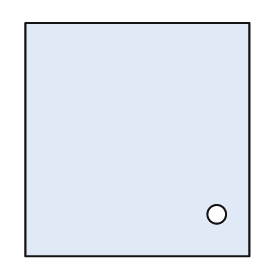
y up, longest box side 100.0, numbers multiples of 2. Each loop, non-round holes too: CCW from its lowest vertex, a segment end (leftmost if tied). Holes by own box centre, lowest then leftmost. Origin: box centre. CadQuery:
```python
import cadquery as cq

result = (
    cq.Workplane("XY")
    .moveTo(-48.0, -50.0)
    .lineTo(48.0, -50.0)
    .lineTo(48.0, 50.0)
    .lineTo(-48.0, 50.0)
    .close()
    .moveTo(34.0, -32.0)
    .circle(4.0)
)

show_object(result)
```